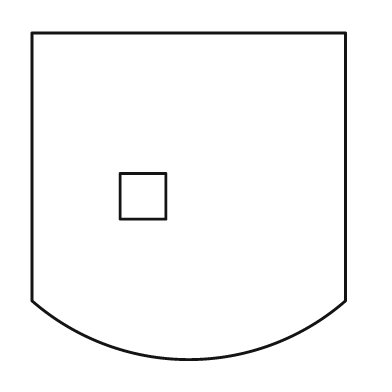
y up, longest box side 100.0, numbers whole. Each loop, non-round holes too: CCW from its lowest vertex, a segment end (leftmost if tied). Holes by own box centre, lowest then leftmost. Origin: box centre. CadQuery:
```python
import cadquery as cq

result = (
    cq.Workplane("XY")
    .moveTo(-48.0, -32.0)
    .threePointArc((0.0, -50.0), (48.0, -32.0))
    .lineTo(48.0, 50.0)
    .lineTo(-48.0, 50.0)
    .close()
    .moveTo(-21.0, -7.0)
    .lineTo(-7.0, -7.0)
    .lineTo(-7.0, 7.0)
    .lineTo(-21.0, 7.0)
    .close()
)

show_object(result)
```